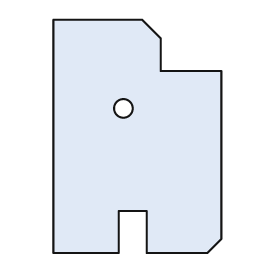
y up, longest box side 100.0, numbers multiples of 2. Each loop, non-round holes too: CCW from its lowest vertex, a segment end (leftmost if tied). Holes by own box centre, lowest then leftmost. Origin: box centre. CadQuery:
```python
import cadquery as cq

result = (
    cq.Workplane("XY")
    .moveTo(-36.0, -50.0)
    .lineTo(-8.0, -50.0)
    .lineTo(-8.0, -32.0)
    .lineTo(4.0, -32.0)
    .lineTo(4.0, -50.0)
    .lineTo(30.0, -50.0)
    .lineTo(36.0, -44.0)
    .lineTo(36.0, 28.0)
    .lineTo(10.0, 28.0)
    .lineTo(10.0, 42.0)
    .lineTo(2.0, 50.0)
    .lineTo(-36.0, 50.0)
    .close()
    .moveTo(-6.0, 12.0)
    .circle(4.0)
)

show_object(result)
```